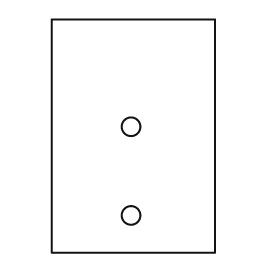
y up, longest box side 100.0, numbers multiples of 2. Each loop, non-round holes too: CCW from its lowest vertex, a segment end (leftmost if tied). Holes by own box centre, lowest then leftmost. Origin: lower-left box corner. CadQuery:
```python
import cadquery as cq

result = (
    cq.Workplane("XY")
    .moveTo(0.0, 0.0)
    .lineTo(70.0, 0.0)
    .lineTo(70.0, 100.0)
    .lineTo(0.0, 100.0)
    .close()
    .moveTo(34.0, 16.0)
    .circle(4.0)
    .moveTo(34.0, 54.0)
    .circle(4.0)
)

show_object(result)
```